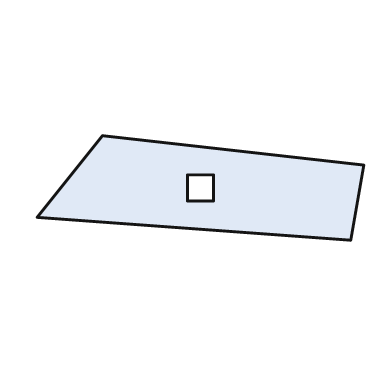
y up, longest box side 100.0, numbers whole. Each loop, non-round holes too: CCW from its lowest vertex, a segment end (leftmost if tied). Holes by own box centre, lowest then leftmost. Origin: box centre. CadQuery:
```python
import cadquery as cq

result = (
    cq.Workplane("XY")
    .moveTo(46.0, -16.0)
    .lineTo(50.0, 7.0)
    .lineTo(-30.0, 16.0)
    .lineTo(-50.0, -9.0)
    .close()
    .moveTo(-4.0, -4.0)
    .lineTo(4.0, -4.0)
    .lineTo(4.0, 4.0)
    .lineTo(-4.0, 4.0)
    .close()
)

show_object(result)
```